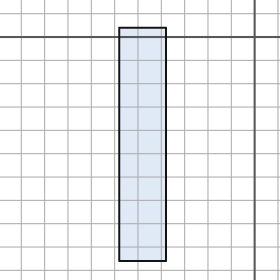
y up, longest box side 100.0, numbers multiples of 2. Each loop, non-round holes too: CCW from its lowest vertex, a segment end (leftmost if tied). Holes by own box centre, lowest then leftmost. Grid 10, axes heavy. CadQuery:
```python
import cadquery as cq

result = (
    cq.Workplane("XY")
    .moveTo(-58.0, -96.0)
    .lineTo(-38.0, -96.0)
    .lineTo(-38.0, 4.0)
    .lineTo(-58.0, 4.0)
    .close()
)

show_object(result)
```